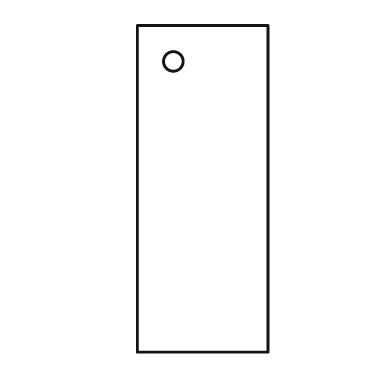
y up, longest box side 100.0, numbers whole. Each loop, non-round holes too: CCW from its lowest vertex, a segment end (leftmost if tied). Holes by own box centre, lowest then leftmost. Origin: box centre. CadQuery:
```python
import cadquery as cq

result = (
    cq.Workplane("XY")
    .moveTo(-20.0, -50.0)
    .lineTo(20.0, -50.0)
    .lineTo(20.0, 50.0)
    .lineTo(-20.0, 50.0)
    .close()
    .moveTo(-9.0, 39.0)
    .circle(3.0)
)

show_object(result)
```